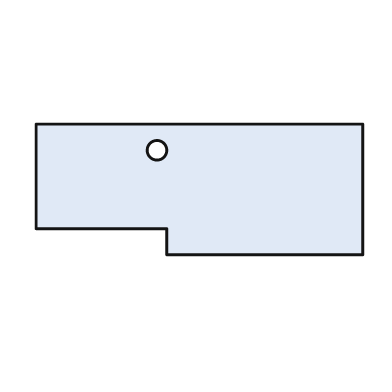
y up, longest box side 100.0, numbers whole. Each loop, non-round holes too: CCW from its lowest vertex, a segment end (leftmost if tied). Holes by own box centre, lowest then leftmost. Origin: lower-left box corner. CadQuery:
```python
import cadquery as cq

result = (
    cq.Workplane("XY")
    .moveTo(40.0, 0.0)
    .lineTo(100.0, 0.0)
    .lineTo(100.0, 40.0)
    .lineTo(0.0, 40.0)
    .lineTo(0.0, 8.0)
    .lineTo(40.0, 8.0)
    .close()
    .moveTo(37.0, 32.0)
    .circle(3.0)
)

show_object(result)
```